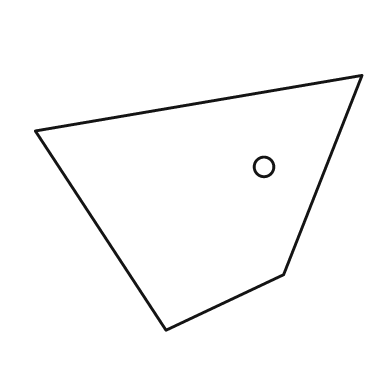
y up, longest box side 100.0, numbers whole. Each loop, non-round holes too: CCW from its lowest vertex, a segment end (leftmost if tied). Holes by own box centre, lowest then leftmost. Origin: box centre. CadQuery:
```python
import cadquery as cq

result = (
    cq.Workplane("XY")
    .moveTo(-10.0, -39.0)
    .lineTo(26.0, -22.0)
    .lineTo(50.0, 39.0)
    .lineTo(-50.0, 22.0)
    .close()
    .moveTo(20.0, 11.0)
    .circle(3.0)
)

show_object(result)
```